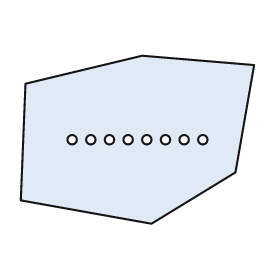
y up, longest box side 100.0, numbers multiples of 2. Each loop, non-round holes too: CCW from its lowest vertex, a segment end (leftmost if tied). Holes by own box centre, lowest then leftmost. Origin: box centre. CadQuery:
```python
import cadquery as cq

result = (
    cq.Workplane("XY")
    .moveTo(6.0, -36.0)
    .lineTo(42.0, -14.0)
    .lineTo(50.0, 32.0)
    .lineTo(2.0, 36.0)
    .lineTo(-48.0, 24.0)
    .lineTo(-50.0, -26.0)
    .close()
    .moveTo(-28.0, 0.0)
    .circle(2.0)
    .moveTo(-20.0, 0.0)
    .circle(2.0)
    .moveTo(-12.0, 0.0)
    .circle(2.0)
    .moveTo(-4.0, 0.0)
    .circle(2.0)
    .moveTo(4.0, 0.0)
    .circle(2.0)
    .moveTo(12.0, 0.0)
    .circle(2.0)
    .moveTo(20.0, 0.0)
    .circle(2.0)
    .moveTo(28.0, 0.0)
    .circle(2.0)
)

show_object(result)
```